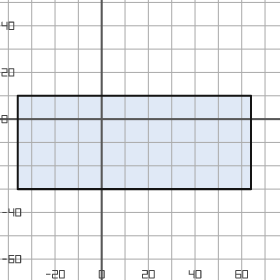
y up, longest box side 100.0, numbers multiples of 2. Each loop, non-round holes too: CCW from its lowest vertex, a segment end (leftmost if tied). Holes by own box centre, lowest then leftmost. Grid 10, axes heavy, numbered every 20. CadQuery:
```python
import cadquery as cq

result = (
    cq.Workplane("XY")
    .moveTo(-36.0, -30.0)
    .lineTo(64.0, -30.0)
    .lineTo(64.0, 10.0)
    .lineTo(-36.0, 10.0)
    .close()
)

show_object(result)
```